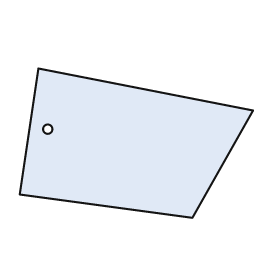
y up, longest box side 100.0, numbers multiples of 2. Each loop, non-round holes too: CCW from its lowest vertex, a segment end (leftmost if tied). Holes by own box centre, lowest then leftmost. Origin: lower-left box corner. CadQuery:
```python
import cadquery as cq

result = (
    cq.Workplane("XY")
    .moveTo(74.0, 0.0)
    .lineTo(100.0, 46.0)
    .lineTo(8.0, 64.0)
    .lineTo(0.0, 10.0)
    .close()
    .moveTo(12.0, 38.0)
    .circle(2.0)
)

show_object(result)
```